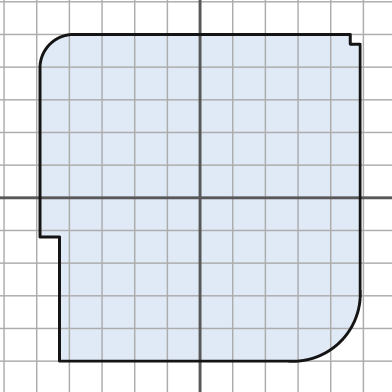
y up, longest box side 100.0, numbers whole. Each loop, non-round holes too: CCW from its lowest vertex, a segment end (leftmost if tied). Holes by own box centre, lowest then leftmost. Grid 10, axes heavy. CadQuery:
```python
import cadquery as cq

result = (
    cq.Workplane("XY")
    .moveTo(-43.0, -50.0)
    .lineTo(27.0, -50.0)
    .threePointArc((43.0, -44.0), (49.0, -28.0))
    .lineTo(49.0, 47.0)
    .lineTo(46.0, 47.0)
    .lineTo(46.0, 50.0)
    .lineTo(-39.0, 50.0)
    .threePointArc((-46.0, 47.0), (-49.0, 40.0))
    .lineTo(-49.0, -12.0)
    .lineTo(-43.0, -12.0)
    .close()
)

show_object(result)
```